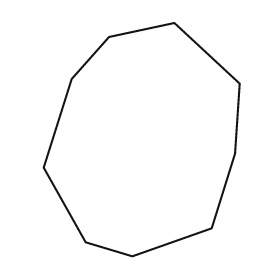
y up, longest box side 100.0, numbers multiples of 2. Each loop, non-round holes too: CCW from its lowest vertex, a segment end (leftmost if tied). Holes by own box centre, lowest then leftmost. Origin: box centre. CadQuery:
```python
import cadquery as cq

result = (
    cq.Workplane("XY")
    .moveTo(-4.0, -50.0)
    .lineTo(30.0, -38.0)
    .lineTo(40.0, -6.0)
    .lineTo(42.0, 24.0)
    .lineTo(14.0, 50.0)
    .lineTo(-14.0, 44.0)
    .lineTo(-30.0, 26.0)
    .lineTo(-42.0, -12.0)
    .lineTo(-24.0, -44.0)
    .close()
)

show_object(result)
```